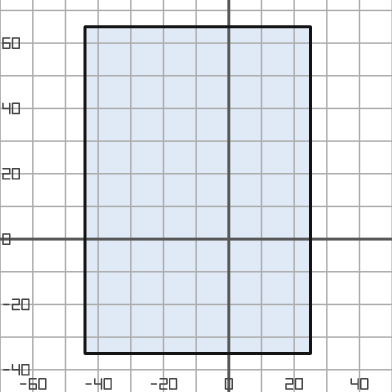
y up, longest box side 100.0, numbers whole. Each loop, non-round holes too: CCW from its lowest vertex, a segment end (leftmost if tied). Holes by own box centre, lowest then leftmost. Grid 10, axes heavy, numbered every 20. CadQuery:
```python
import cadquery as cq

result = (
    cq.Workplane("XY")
    .moveTo(-44.0, -35.0)
    .lineTo(25.0, -35.0)
    .lineTo(25.0, 65.0)
    .lineTo(-44.0, 65.0)
    .close()
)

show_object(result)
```